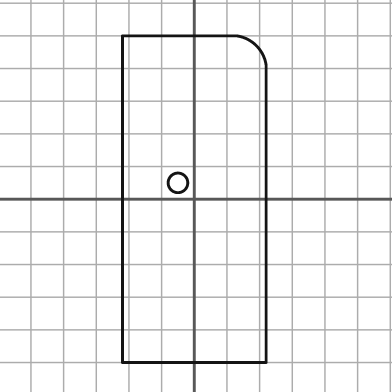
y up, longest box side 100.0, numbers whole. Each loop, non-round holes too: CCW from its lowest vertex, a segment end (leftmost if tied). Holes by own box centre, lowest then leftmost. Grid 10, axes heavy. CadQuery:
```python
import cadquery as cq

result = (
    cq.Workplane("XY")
    .moveTo(-22.0, -50.0)
    .lineTo(22.0, -50.0)
    .lineTo(22.0, 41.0)
    .threePointArc((19.0, 47.0), (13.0, 50.0))
    .lineTo(-22.0, 50.0)
    .close()
    .moveTo(-5.0, 5.0)
    .circle(3.0)
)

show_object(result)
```